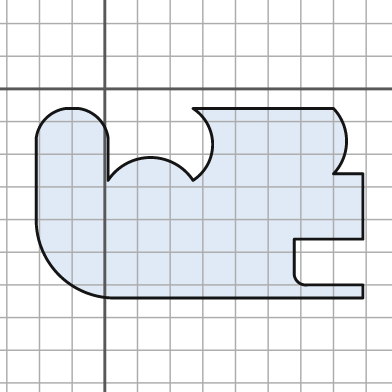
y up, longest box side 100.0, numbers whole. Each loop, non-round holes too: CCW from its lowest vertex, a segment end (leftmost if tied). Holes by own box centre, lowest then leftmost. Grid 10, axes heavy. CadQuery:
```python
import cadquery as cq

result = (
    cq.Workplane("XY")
    .moveTo(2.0, -64.0)
    .lineTo(79.0, -64.0)
    .lineTo(79.0, -60.0)
    .lineTo(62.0, -60.0)
    .threePointArc((59.0, -59.0), (58.0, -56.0))
    .lineTo(58.0, -46.0)
    .lineTo(79.0, -46.0)
    .lineTo(79.0, -26.0)
    .lineTo(70.0, -26.0)
    .threePointArc((74.0, -16.0), (70.0, -6.0))
    .lineTo(27.0, -6.0)
    .threePointArc((33.0, -17.0), (27.0, -28.0))
    .threePointArc((14.0, -21.0), (1.0, -28.0))
    .lineTo(1.0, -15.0)
    .threePointArc((-2.0, -9.0), (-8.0, -6.0))
    .lineTo(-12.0, -6.0)
    .threePointArc((-18.0, -9.0), (-21.0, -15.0))
    .lineTo(-21.0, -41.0)
    .threePointArc((-14.0, -57.0), (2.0, -64.0))
    .close()
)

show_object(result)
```